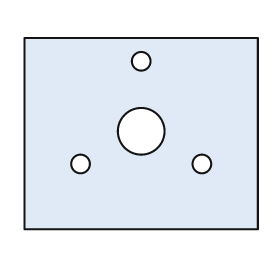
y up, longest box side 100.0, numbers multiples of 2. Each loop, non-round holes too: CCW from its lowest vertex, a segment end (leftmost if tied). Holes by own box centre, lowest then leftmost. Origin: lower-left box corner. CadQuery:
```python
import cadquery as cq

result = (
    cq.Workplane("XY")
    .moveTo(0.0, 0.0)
    .lineTo(100.0, 0.0)
    .lineTo(100.0, 82.0)
    .lineTo(0.0, 82.0)
    .close()
    .moveTo(24.0, 28.0)
    .circle(4.0)
    .moveTo(76.0, 28.0)
    .circle(4.0)
    .moveTo(50.0, 42.0)
    .circle(10.0)
    .moveTo(50.0, 72.0)
    .circle(4.0)
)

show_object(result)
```